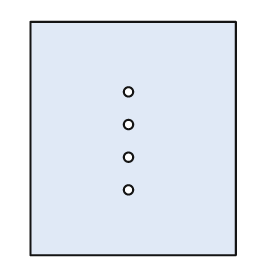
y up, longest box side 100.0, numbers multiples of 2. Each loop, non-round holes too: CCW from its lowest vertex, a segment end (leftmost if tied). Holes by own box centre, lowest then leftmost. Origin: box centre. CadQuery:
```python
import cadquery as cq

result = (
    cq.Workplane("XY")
    .moveTo(-44.0, -50.0)
    .lineTo(44.0, -50.0)
    .lineTo(44.0, 50.0)
    .lineTo(-44.0, 50.0)
    .close()
    .moveTo(-2.0, -22.0)
    .circle(2.0)
    .moveTo(-2.0, -8.0)
    .circle(2.0)
    .moveTo(-2.0, 6.0)
    .circle(2.0)
    .moveTo(-2.0, 20.0)
    .circle(2.0)
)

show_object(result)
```